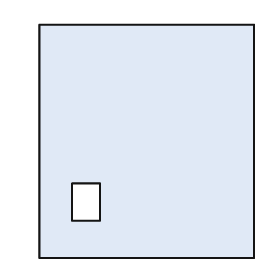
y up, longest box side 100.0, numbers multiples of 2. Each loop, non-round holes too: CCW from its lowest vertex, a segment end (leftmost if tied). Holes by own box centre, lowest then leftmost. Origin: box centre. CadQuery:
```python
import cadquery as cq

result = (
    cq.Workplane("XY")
    .moveTo(-46.0, -50.0)
    .lineTo(46.0, -50.0)
    .lineTo(46.0, 50.0)
    .lineTo(-46.0, 50.0)
    .close()
    .moveTo(-32.0, -34.0)
    .lineTo(-20.0, -34.0)
    .lineTo(-20.0, -18.0)
    .lineTo(-32.0, -18.0)
    .close()
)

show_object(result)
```